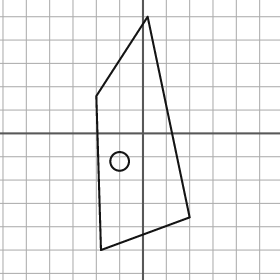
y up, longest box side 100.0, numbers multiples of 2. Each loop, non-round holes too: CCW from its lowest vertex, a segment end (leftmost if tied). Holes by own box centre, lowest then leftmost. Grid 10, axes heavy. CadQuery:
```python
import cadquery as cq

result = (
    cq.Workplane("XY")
    .moveTo(-18.0, -50.0)
    .lineTo(20.0, -36.0)
    .lineTo(2.0, 50.0)
    .lineTo(-20.0, 16.0)
    .close()
    .moveTo(-10.0, -12.0)
    .circle(4.0)
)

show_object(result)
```